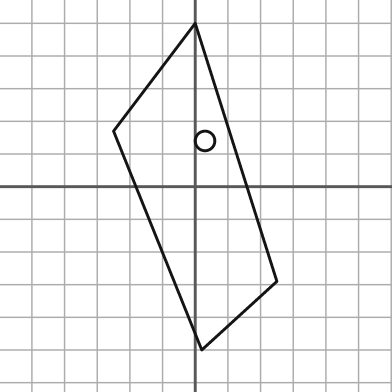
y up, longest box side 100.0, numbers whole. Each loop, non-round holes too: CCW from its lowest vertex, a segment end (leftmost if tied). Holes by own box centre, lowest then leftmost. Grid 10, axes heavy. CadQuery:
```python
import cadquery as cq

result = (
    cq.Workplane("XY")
    .moveTo(2.0, -50.0)
    .lineTo(25.0, -29.0)
    .lineTo(0.0, 50.0)
    .lineTo(-25.0, 17.0)
    .close()
    .moveTo(3.0, 14.0)
    .circle(3.0)
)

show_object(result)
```